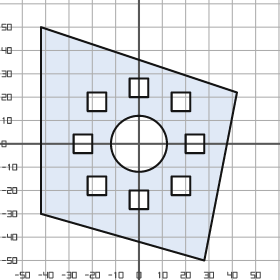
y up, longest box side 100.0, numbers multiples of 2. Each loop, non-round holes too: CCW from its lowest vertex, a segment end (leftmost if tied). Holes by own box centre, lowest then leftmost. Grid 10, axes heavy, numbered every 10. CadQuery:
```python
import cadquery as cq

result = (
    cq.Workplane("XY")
    .moveTo(28.0, -50.0)
    .lineTo(42.0, 22.0)
    .lineTo(-42.0, 50.0)
    .lineTo(-42.0, -30.0)
    .close()
    .moveTo(-4.0, -28.0)
    .lineTo(4.0, -28.0)
    .lineTo(4.0, -20.0)
    .lineTo(-4.0, -20.0)
    .close()
    .moveTo(-22.0, -22.0)
    .lineTo(-14.0, -22.0)
    .lineTo(-14.0, -14.0)
    .lineTo(-22.0, -14.0)
    .close()
    .moveTo(14.0, -22.0)
    .lineTo(22.0, -22.0)
    .lineTo(22.0, -14.0)
    .lineTo(14.0, -14.0)
    .close()
    .moveTo(-28.0, -4.0)
    .lineTo(-20.0, -4.0)
    .lineTo(-20.0, 4.0)
    .lineTo(-28.0, 4.0)
    .close()
    .moveTo(0.0, 0.0)
    .circle(12.0)
    .moveTo(20.0, -4.0)
    .lineTo(28.0, -4.0)
    .lineTo(28.0, 4.0)
    .lineTo(20.0, 4.0)
    .close()
    .moveTo(-22.0, 14.0)
    .lineTo(-14.0, 14.0)
    .lineTo(-14.0, 22.0)
    .lineTo(-22.0, 22.0)
    .close()
    .moveTo(14.0, 14.0)
    .lineTo(22.0, 14.0)
    .lineTo(22.0, 22.0)
    .lineTo(14.0, 22.0)
    .close()
    .moveTo(-4.0, 20.0)
    .lineTo(4.0, 20.0)
    .lineTo(4.0, 28.0)
    .lineTo(-4.0, 28.0)
    .close()
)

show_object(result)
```